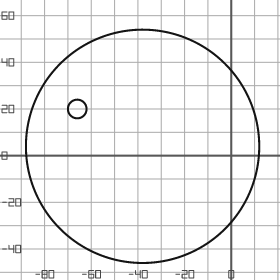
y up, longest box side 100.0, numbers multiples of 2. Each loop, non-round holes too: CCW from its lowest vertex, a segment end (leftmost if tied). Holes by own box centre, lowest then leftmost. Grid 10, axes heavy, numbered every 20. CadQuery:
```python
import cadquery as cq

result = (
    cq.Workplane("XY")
    .moveTo(-38.0, 4.0)
    .circle(50.0)
    .moveTo(-66.0, 20.0)
    .circle(4.0)
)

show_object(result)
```